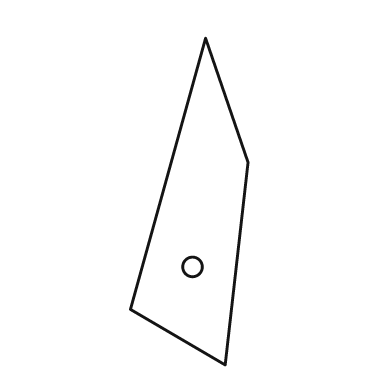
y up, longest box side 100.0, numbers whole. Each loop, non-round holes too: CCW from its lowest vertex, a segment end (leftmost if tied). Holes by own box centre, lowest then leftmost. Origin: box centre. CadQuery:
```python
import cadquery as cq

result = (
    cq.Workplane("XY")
    .moveTo(11.0, -50.0)
    .lineTo(18.0, 12.0)
    .lineTo(5.0, 50.0)
    .lineTo(-18.0, -33.0)
    .close()
    .moveTo(1.0, -20.0)
    .circle(3.0)
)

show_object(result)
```